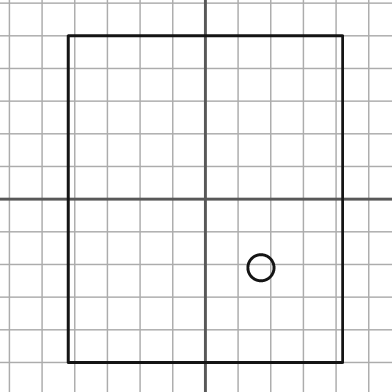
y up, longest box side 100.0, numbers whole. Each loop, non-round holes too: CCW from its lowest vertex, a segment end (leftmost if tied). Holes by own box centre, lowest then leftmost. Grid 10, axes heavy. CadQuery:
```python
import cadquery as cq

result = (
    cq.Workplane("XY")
    .moveTo(-42.0, -50.0)
    .lineTo(42.0, -50.0)
    .lineTo(42.0, 50.0)
    .lineTo(-42.0, 50.0)
    .close()
    .moveTo(17.0, -21.0)
    .circle(4.0)
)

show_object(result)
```